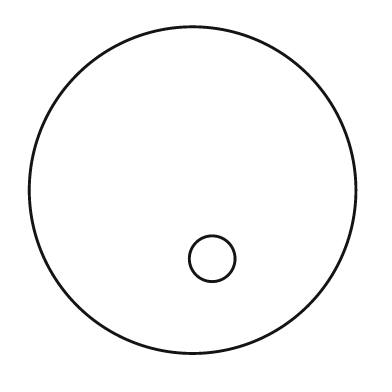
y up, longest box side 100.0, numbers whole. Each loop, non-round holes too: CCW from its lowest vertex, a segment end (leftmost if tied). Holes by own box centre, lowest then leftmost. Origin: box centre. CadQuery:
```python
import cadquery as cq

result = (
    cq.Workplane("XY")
    .moveTo(0.0, 0.0)
    .circle(50.0)
    .moveTo(6.0, -21.0)
    .circle(7.0)
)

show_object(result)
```